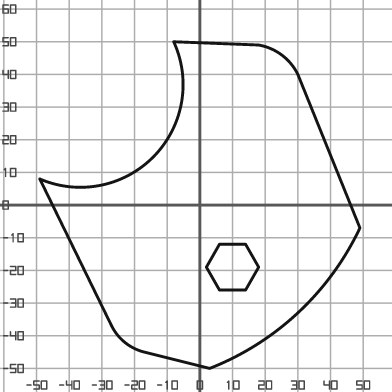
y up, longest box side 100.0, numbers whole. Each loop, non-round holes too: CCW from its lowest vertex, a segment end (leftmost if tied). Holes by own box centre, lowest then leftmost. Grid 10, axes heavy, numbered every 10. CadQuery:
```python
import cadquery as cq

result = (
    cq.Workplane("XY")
    .moveTo(3.0, -50.0)
    .threePointArc((30.0, -33.0), (49.0, -7.0))
    .lineTo(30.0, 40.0)
    .threePointArc((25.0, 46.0), (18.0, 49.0))
    .lineTo(-8.0, 50.0)
    .threePointArc((-14.0, 15.0), (-49.0, 8.0))
    .lineTo(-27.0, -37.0)
    .threePointArc((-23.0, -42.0), (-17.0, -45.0))
    .close()
    .moveTo(6.0, -26.0)
    .lineTo(14.0, -26.0)
    .lineTo(18.0, -19.0)
    .lineTo(14.0, -12.0)
    .lineTo(6.0, -12.0)
    .lineTo(2.0, -19.0)
    .close()
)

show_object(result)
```